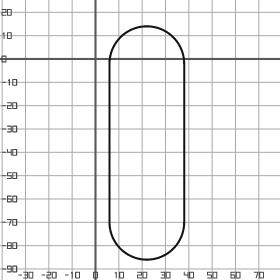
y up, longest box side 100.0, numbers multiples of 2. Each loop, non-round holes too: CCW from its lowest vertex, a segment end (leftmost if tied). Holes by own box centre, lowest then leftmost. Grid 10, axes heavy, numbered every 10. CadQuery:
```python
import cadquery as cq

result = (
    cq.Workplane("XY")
    .moveTo(6.0, -70.0)
    .threePointArc((22.0, -86.0), (38.0, -70.0))
    .lineTo(38.0, -2.0)
    .threePointArc((22.0, 14.0), (6.0, -2.0))
    .close()
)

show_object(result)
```